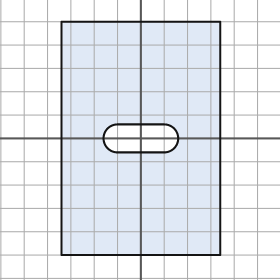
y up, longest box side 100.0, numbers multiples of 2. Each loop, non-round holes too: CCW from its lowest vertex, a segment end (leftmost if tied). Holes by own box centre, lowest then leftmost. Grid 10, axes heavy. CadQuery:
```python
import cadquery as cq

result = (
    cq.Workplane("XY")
    .moveTo(-34.0, -50.0)
    .lineTo(34.0, -50.0)
    .lineTo(34.0, 50.0)
    .lineTo(-34.0, 50.0)
    .close()
    .moveTo(-10.0, -6.0)
    .lineTo(10.0, -6.0)
    .threePointArc((16.0, 0.0), (10.0, 6.0))
    .lineTo(-10.0, 6.0)
    .threePointArc((-16.0, 0.0), (-10.0, -6.0))
    .close()
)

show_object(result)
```